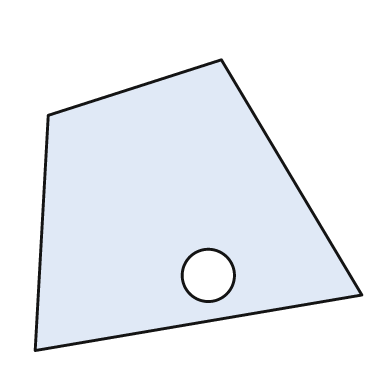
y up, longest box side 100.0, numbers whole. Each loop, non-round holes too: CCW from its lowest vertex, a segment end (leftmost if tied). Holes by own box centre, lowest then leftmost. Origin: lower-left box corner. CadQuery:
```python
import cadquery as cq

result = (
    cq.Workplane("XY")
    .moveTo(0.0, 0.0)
    .lineTo(100.0, 17.0)
    .lineTo(57.0, 89.0)
    .lineTo(4.0, 72.0)
    .close()
    .moveTo(53.0, 23.0)
    .circle(8.0)
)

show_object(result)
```